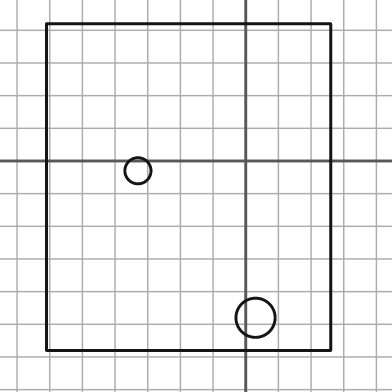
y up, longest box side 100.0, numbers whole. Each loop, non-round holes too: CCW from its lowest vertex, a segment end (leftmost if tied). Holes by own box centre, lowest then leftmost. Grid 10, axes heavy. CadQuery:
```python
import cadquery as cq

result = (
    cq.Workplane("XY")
    .moveTo(-61.0, -58.0)
    .lineTo(26.0, -58.0)
    .lineTo(26.0, 42.0)
    .lineTo(-61.0, 42.0)
    .close()
    .moveTo(3.0, -48.0)
    .circle(6.0)
    .moveTo(-33.0, -3.0)
    .circle(4.0)
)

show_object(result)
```